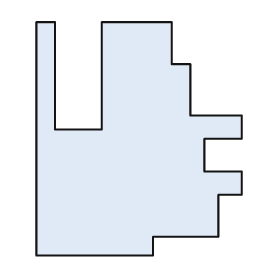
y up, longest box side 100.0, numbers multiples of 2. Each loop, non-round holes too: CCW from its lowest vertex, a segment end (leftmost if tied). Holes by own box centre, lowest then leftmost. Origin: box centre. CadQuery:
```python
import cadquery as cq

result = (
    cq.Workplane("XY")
    .moveTo(-44.0, -50.0)
    .lineTo(6.0, -50.0)
    .lineTo(6.0, -42.0)
    .lineTo(34.0, -42.0)
    .lineTo(34.0, -24.0)
    .lineTo(44.0, -24.0)
    .lineTo(44.0, -14.0)
    .lineTo(28.0, -14.0)
    .lineTo(28.0, 0.0)
    .lineTo(44.0, 0.0)
    .lineTo(44.0, 10.0)
    .lineTo(22.0, 10.0)
    .lineTo(22.0, 32.0)
    .lineTo(14.0, 32.0)
    .lineTo(14.0, 50.0)
    .lineTo(-16.0, 50.0)
    .lineTo(-16.0, 4.0)
    .lineTo(-36.0, 4.0)
    .lineTo(-36.0, 50.0)
    .lineTo(-44.0, 50.0)
    .close()
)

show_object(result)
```